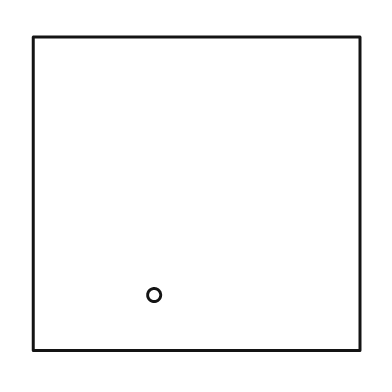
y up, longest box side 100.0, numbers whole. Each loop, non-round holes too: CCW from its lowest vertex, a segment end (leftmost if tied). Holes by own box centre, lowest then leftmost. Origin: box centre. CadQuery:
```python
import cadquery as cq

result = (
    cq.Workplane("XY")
    .moveTo(-50.0, -48.0)
    .lineTo(50.0, -48.0)
    .lineTo(50.0, 48.0)
    .lineTo(-50.0, 48.0)
    .close()
    .moveTo(-13.0, -31.0)
    .circle(2.0)
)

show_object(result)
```